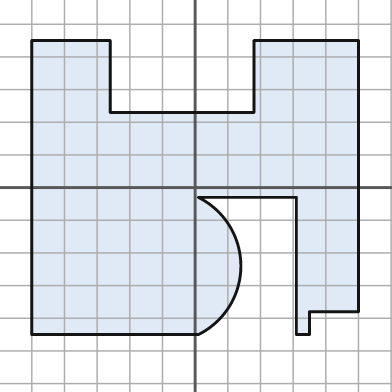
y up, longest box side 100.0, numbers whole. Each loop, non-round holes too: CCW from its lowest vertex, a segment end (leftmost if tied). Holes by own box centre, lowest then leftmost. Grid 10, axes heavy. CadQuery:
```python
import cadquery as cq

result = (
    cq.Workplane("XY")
    .moveTo(-50.0, -45.0)
    .lineTo(1.0, -45.0)
    .threePointArc((14.0, -24.0), (1.0, -3.0))
    .lineTo(31.0, -3.0)
    .lineTo(31.0, -45.0)
    .lineTo(35.0, -45.0)
    .lineTo(35.0, -38.0)
    .lineTo(50.0, -38.0)
    .lineTo(50.0, 45.0)
    .lineTo(18.0, 45.0)
    .lineTo(18.0, 23.0)
    .lineTo(-26.0, 23.0)
    .lineTo(-26.0, 45.0)
    .lineTo(-50.0, 45.0)
    .close()
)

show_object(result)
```